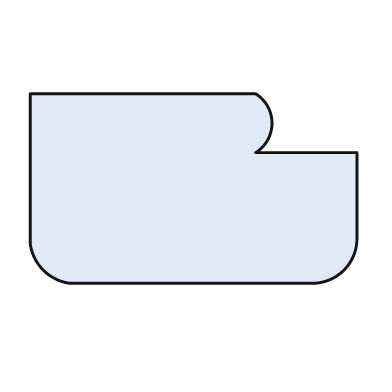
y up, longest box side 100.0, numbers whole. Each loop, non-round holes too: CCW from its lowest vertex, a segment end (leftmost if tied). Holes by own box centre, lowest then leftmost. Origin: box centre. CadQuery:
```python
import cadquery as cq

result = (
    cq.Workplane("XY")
    .moveTo(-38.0, -29.0)
    .lineTo(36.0, -29.0)
    .threePointArc((46.0, -25.0), (50.0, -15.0))
    .lineTo(50.0, 11.0)
    .lineTo(19.0, 11.0)
    .threePointArc((24.0, 20.0), (19.0, 29.0))
    .lineTo(-50.0, 29.0)
    .lineTo(-50.0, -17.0)
    .threePointArc((-46.0, -25.0), (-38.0, -29.0))
    .close()
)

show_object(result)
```